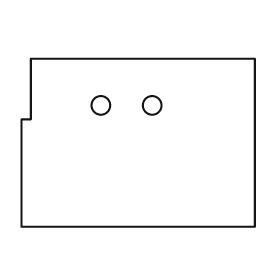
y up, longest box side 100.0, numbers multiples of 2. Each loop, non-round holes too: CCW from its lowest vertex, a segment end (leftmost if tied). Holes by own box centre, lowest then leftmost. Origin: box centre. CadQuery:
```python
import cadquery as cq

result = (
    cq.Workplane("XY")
    .moveTo(-50.0, -36.0)
    .lineTo(50.0, -36.0)
    .lineTo(50.0, 36.0)
    .lineTo(-46.0, 36.0)
    .lineTo(-46.0, 10.0)
    .lineTo(-50.0, 10.0)
    .close()
    .moveTo(-16.0, 16.0)
    .circle(4.0)
    .moveTo(6.0, 16.0)
    .circle(4.0)
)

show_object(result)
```